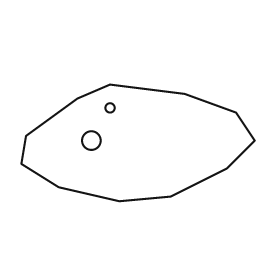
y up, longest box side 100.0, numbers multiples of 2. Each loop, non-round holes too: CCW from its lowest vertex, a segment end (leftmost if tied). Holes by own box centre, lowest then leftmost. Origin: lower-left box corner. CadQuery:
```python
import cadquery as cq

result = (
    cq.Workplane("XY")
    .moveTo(42.0, 0.0)
    .lineTo(64.0, 2.0)
    .lineTo(88.0, 14.0)
    .lineTo(100.0, 26.0)
    .lineTo(92.0, 38.0)
    .lineTo(70.0, 46.0)
    .lineTo(38.0, 50.0)
    .lineTo(24.0, 44.0)
    .lineTo(2.0, 28.0)
    .lineTo(0.0, 16.0)
    .lineTo(16.0, 6.0)
    .close()
    .moveTo(30.0, 26.0)
    .circle(4.0)
    .moveTo(38.0, 40.0)
    .circle(2.0)
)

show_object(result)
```